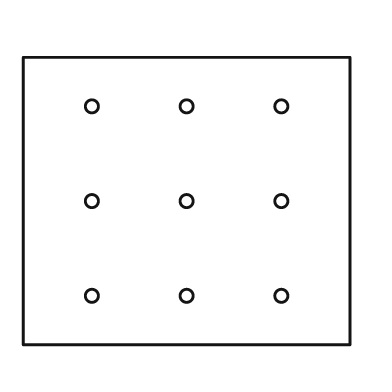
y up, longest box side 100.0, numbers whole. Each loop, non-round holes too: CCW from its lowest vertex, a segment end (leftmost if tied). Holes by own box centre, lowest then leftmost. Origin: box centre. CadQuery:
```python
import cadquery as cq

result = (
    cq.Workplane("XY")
    .moveTo(-50.0, -44.0)
    .lineTo(50.0, -44.0)
    .lineTo(50.0, 44.0)
    .lineTo(-50.0, 44.0)
    .close()
    .moveTo(-29.0, -29.0)
    .circle(2.0)
    .moveTo(0.0, -29.0)
    .circle(2.0)
    .moveTo(29.0, -29.0)
    .circle(2.0)
    .moveTo(-29.0, 0.0)
    .circle(2.0)
    .moveTo(0.0, 0.0)
    .circle(2.0)
    .moveTo(29.0, 0.0)
    .circle(2.0)
    .moveTo(-29.0, 29.0)
    .circle(2.0)
    .moveTo(0.0, 29.0)
    .circle(2.0)
    .moveTo(29.0, 29.0)
    .circle(2.0)
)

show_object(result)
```